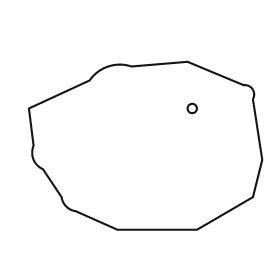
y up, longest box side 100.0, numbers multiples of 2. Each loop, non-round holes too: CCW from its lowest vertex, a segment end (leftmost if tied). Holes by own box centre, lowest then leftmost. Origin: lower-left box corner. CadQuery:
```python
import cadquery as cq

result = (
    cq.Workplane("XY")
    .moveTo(38.0, 0.0)
    .lineTo(72.0, 0.0)
    .lineTo(96.0, 14.0)
    .lineTo(100.0, 30.0)
    .lineTo(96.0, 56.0)
    .threePointArc((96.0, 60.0), (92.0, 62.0))
    .lineTo(68.0, 72.0)
    .lineTo(44.0, 70.0)
    .threePointArc((34.0, 70.0), (26.0, 64.0))
    .lineTo(0.0, 52.0)
    .lineTo(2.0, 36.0)
    .threePointArc((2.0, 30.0), (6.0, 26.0))
    .lineTo(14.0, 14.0)
    .threePointArc((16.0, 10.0), (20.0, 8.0))
    .close()
    .moveTo(70.0, 52.0)
    .circle(2.0)
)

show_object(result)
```